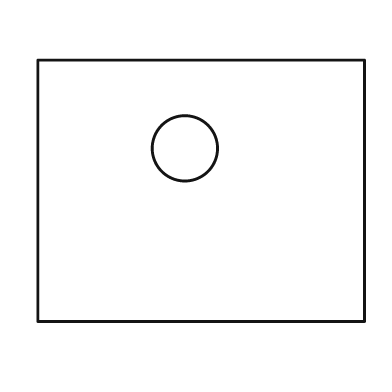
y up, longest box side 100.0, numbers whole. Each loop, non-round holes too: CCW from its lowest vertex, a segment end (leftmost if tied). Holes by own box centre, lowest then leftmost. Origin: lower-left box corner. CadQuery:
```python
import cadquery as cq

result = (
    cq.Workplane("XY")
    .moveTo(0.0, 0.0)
    .lineTo(100.0, 0.0)
    .lineTo(100.0, 80.0)
    .lineTo(0.0, 80.0)
    .close()
    .moveTo(45.0, 53.0)
    .circle(10.0)
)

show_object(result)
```